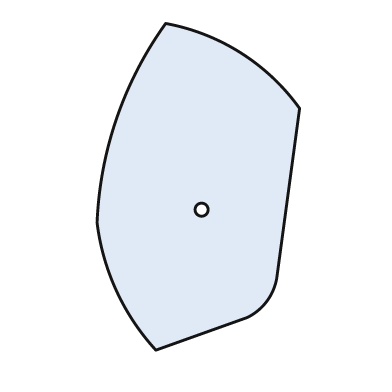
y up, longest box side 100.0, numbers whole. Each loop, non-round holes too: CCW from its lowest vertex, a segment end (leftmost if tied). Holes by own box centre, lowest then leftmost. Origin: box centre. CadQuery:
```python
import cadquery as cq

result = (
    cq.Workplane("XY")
    .moveTo(-13.0, -50.0)
    .lineTo(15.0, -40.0)
    .threePointArc((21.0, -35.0), (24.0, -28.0))
    .lineTo(31.0, 24.0)
    .threePointArc((13.0, 41.0), (-10.0, 50.0))
    .threePointArc((-25.0, 21.0), (-31.0, -11.0))
    .threePointArc((-25.0, -32.0), (-13.0, -50.0))
    .close()
    .moveTo(1.0, -7.0)
    .circle(2.0)
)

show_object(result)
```